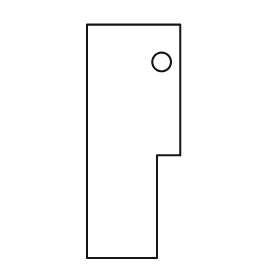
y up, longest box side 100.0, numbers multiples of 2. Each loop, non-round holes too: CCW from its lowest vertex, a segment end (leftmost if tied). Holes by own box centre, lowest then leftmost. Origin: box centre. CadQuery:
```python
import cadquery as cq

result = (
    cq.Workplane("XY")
    .moveTo(-20.0, -50.0)
    .lineTo(10.0, -50.0)
    .lineTo(10.0, -6.0)
    .lineTo(20.0, -6.0)
    .lineTo(20.0, 50.0)
    .lineTo(-20.0, 50.0)
    .close()
    .moveTo(12.0, 34.0)
    .circle(4.0)
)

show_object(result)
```